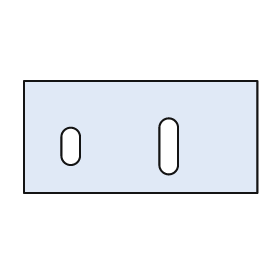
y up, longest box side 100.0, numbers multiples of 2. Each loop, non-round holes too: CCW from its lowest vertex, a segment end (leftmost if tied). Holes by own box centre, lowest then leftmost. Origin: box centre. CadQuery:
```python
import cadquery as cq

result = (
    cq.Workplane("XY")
    .moveTo(-50.0, -24.0)
    .lineTo(50.0, -24.0)
    .lineTo(50.0, 24.0)
    .lineTo(-50.0, 24.0)
    .close()
    .moveTo(-34.0, -8.0)
    .threePointArc((-30.0, -12.0), (-26.0, -8.0))
    .lineTo(-26.0, 0.0)
    .threePointArc((-30.0, 4.0), (-34.0, 0.0))
    .close()
    .moveTo(8.0, -12.0)
    .threePointArc((12.0, -16.0), (16.0, -12.0))
    .lineTo(16.0, 4.0)
    .threePointArc((12.0, 8.0), (8.0, 4.0))
    .close()
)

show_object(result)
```